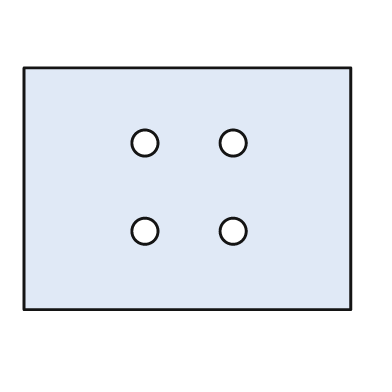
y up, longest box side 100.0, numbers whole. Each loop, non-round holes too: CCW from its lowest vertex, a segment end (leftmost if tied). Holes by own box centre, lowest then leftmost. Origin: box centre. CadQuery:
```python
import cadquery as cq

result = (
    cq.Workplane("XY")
    .moveTo(-50.0, -37.0)
    .lineTo(50.0, -37.0)
    .lineTo(50.0, 37.0)
    .lineTo(-50.0, 37.0)
    .close()
    .moveTo(-13.0, -13.0)
    .circle(4.0)
    .moveTo(14.0, -13.0)
    .circle(4.0)
    .moveTo(-13.0, 14.0)
    .circle(4.0)
    .moveTo(14.0, 14.0)
    .circle(4.0)
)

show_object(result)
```